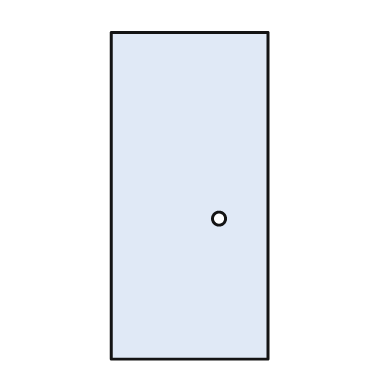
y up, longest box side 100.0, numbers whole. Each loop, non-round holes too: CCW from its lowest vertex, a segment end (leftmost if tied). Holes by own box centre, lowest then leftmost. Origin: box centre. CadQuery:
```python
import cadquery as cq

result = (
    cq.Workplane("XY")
    .moveTo(-24.0, -50.0)
    .lineTo(24.0, -50.0)
    .lineTo(24.0, 50.0)
    .lineTo(-24.0, 50.0)
    .close()
    .moveTo(9.0, -7.0)
    .circle(2.0)
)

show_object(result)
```